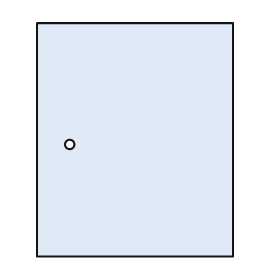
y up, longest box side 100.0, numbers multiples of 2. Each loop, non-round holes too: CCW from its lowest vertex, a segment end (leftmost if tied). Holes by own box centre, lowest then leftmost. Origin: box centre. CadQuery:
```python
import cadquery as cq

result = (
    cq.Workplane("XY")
    .moveTo(-42.0, -50.0)
    .lineTo(42.0, -50.0)
    .lineTo(42.0, 50.0)
    .lineTo(-42.0, 50.0)
    .close()
    .moveTo(-28.0, -2.0)
    .circle(2.0)
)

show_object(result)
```